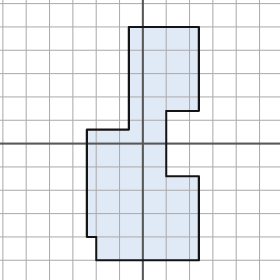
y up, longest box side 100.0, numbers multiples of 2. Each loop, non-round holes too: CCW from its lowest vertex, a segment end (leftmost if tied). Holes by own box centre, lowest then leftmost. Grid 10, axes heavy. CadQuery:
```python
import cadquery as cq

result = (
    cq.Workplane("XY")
    .moveTo(-20.0, -50.0)
    .lineTo(24.0, -50.0)
    .lineTo(24.0, -14.0)
    .lineTo(10.0, -14.0)
    .lineTo(10.0, 14.0)
    .lineTo(24.0, 14.0)
    .lineTo(24.0, 50.0)
    .lineTo(-6.0, 50.0)
    .lineTo(-6.0, 6.0)
    .lineTo(-24.0, 6.0)
    .lineTo(-24.0, -40.0)
    .lineTo(-20.0, -40.0)
    .close()
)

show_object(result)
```